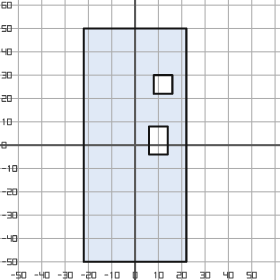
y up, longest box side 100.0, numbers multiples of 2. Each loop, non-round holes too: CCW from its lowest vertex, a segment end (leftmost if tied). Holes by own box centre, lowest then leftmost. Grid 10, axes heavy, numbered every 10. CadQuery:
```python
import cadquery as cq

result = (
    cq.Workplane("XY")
    .moveTo(-22.0, -50.0)
    .lineTo(22.0, -50.0)
    .lineTo(22.0, 50.0)
    .lineTo(-22.0, 50.0)
    .close()
    .moveTo(6.0, -4.0)
    .lineTo(14.0, -4.0)
    .lineTo(14.0, 8.0)
    .lineTo(6.0, 8.0)
    .close()
    .moveTo(8.0, 22.0)
    .lineTo(16.0, 22.0)
    .lineTo(16.0, 30.0)
    .lineTo(8.0, 30.0)
    .close()
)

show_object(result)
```